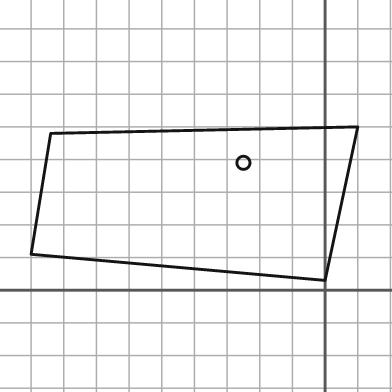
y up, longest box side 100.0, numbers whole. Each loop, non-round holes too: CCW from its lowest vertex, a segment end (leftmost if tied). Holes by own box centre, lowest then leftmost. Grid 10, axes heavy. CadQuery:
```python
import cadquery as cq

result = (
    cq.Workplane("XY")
    .moveTo(0.0, 3.0)
    .lineTo(10.0, 50.0)
    .lineTo(-84.0, 48.0)
    .lineTo(-90.0, 11.0)
    .close()
    .moveTo(-25.0, 39.0)
    .circle(2.0)
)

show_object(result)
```